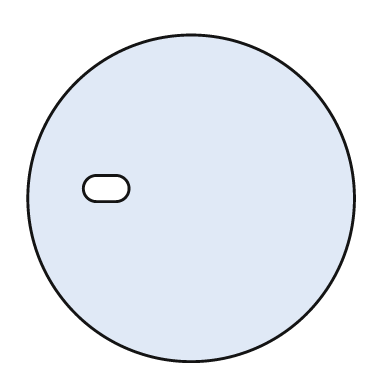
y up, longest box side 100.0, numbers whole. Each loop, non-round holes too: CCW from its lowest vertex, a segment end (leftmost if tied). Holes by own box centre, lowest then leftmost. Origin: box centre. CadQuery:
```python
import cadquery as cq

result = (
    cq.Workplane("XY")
    .moveTo(0.0, 0.0)
    .circle(50.0)
    .moveTo(-29.0, -1.0)
    .lineTo(-23.0, -1.0)
    .threePointArc((-19.0, 3.0), (-23.0, 7.0))
    .lineTo(-29.0, 7.0)
    .threePointArc((-33.0, 3.0), (-29.0, -1.0))
    .close()
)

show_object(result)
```